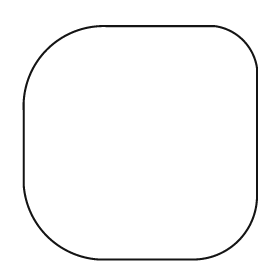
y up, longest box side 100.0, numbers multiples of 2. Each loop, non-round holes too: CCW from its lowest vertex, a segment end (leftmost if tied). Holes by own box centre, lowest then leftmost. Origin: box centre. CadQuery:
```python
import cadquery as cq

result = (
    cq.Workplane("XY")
    .moveTo(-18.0, -50.0)
    .lineTo(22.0, -50.0)
    .threePointArc((42.0, -42.0), (50.0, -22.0))
    .lineTo(50.0, 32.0)
    .threePointArc((44.0, 44.0), (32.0, 50.0))
    .lineTo(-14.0, 50.0)
    .threePointArc((-40.0, 40.0), (-50.0, 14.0))
    .lineTo(-50.0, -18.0)
    .threePointArc((-40.0, -40.0), (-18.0, -50.0))
    .close()
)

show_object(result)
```